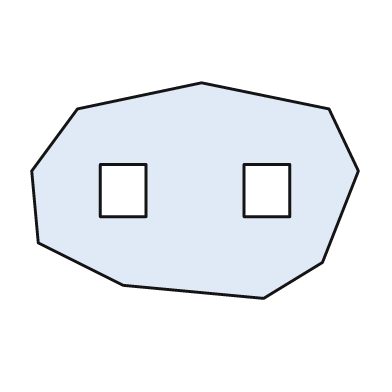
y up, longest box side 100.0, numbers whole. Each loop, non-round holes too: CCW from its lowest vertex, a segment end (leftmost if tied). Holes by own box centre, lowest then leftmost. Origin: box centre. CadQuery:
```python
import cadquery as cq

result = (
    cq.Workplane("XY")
    .moveTo(21.0, -33.0)
    .lineTo(39.0, -22.0)
    .lineTo(50.0, 6.0)
    .lineTo(41.0, 25.0)
    .lineTo(2.0, 33.0)
    .lineTo(-36.0, 25.0)
    .lineTo(-50.0, 6.0)
    .lineTo(-48.0, -16.0)
    .lineTo(-22.0, -29.0)
    .close()
    .moveTo(-29.0, -8.0)
    .lineTo(-15.0, -8.0)
    .lineTo(-15.0, 8.0)
    .lineTo(-29.0, 8.0)
    .close()
    .moveTo(15.0, -8.0)
    .lineTo(29.0, -8.0)
    .lineTo(29.0, 8.0)
    .lineTo(15.0, 8.0)
    .close()
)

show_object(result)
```